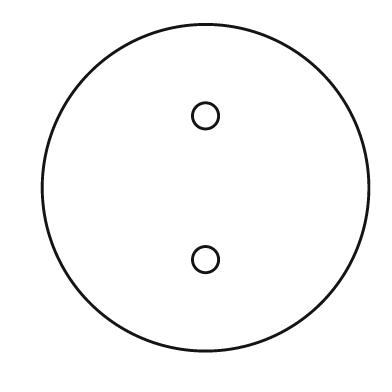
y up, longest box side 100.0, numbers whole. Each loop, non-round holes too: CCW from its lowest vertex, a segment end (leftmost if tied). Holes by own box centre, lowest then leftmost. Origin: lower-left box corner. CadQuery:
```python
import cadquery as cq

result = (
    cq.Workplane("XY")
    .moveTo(50.0, 50.0)
    .circle(50.0)
    .moveTo(50.0, 28.0)
    .circle(4.0)
    .moveTo(50.0, 72.0)
    .circle(4.0)
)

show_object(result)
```